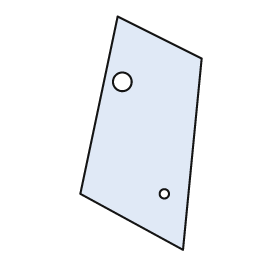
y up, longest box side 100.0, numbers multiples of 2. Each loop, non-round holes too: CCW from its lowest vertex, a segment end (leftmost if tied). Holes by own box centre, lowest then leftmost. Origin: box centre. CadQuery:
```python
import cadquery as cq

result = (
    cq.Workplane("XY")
    .moveTo(18.0, -50.0)
    .lineTo(26.0, 32.0)
    .lineTo(-10.0, 50.0)
    .lineTo(-26.0, -26.0)
    .close()
    .moveTo(10.0, -26.0)
    .circle(2.0)
    .moveTo(-8.0, 22.0)
    .circle(4.0)
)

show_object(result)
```